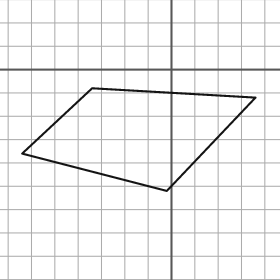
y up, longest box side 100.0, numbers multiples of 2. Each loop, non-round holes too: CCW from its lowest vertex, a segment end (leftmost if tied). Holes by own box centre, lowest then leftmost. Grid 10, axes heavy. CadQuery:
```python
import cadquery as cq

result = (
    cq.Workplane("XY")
    .moveTo(-2.0, -52.0)
    .lineTo(36.0, -12.0)
    .lineTo(-34.0, -8.0)
    .lineTo(-64.0, -36.0)
    .close()
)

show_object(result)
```